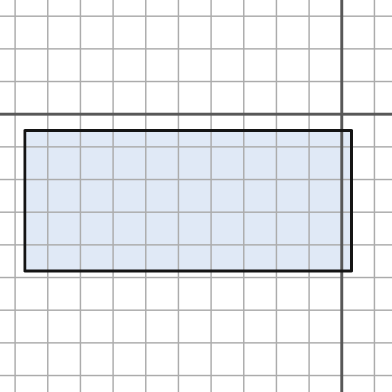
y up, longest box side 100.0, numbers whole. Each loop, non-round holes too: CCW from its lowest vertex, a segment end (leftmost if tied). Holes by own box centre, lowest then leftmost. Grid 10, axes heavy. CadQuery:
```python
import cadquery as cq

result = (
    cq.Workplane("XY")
    .moveTo(-97.0, -48.0)
    .lineTo(3.0, -48.0)
    .lineTo(3.0, -5.0)
    .lineTo(-97.0, -5.0)
    .close()
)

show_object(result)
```